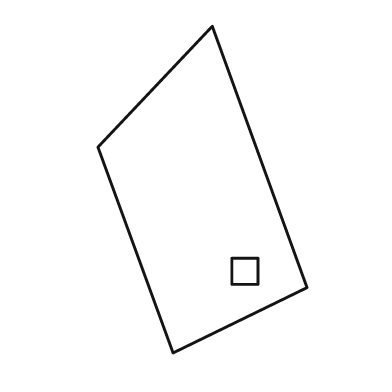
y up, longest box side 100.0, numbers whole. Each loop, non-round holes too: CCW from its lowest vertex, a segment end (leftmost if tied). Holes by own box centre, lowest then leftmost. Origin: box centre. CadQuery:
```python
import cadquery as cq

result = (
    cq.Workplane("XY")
    .moveTo(-9.0, -50.0)
    .lineTo(32.0, -30.0)
    .lineTo(3.0, 50.0)
    .lineTo(-32.0, 13.0)
    .close()
    .moveTo(9.0, -29.0)
    .lineTo(17.0, -29.0)
    .lineTo(17.0, -21.0)
    .lineTo(9.0, -21.0)
    .close()
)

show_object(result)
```